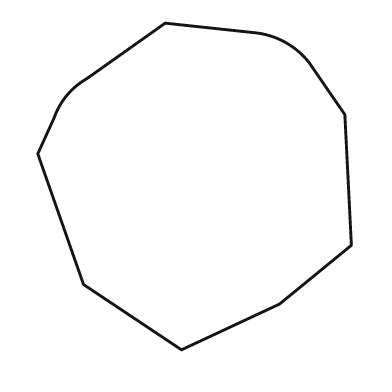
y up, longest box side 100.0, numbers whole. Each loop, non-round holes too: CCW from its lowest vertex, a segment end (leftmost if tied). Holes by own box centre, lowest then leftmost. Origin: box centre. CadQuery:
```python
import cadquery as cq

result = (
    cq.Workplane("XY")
    .moveTo(-4.0, -50.0)
    .lineTo(26.0, -36.0)
    .lineTo(48.0, -18.0)
    .lineTo(46.0, 22.0)
    .lineTo(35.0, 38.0)
    .threePointArc((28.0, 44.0), (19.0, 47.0))
    .lineTo(-9.0, 50.0)
    .lineTo(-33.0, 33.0)
    .threePointArc((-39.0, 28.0), (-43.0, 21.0))
    .lineTo(-48.0, 10.0)
    .lineTo(-34.0, -30.0)
    .close()
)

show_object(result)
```